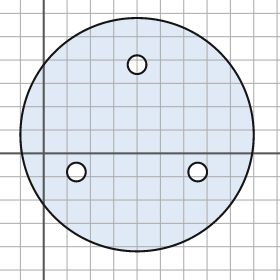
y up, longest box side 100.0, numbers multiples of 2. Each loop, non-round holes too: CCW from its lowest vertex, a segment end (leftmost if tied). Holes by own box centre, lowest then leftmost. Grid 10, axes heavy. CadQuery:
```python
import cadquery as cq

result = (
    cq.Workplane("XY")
    .moveTo(40.0, 8.0)
    .circle(50.0)
    .moveTo(14.0, -8.0)
    .circle(4.0)
    .moveTo(66.0, -8.0)
    .circle(4.0)
    .moveTo(40.0, 38.0)
    .circle(4.0)
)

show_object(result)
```